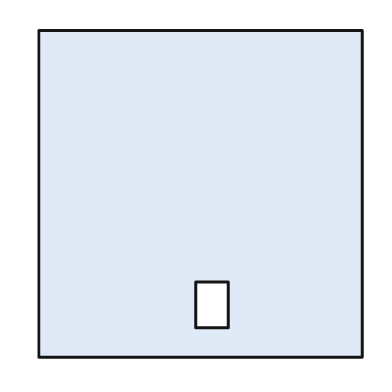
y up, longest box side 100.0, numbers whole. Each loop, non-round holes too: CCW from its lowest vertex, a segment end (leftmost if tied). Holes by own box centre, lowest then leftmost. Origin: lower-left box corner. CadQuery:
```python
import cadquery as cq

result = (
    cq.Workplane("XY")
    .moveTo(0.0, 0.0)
    .lineTo(99.0, 0.0)
    .lineTo(99.0, 100.0)
    .lineTo(0.0, 100.0)
    .close()
    .moveTo(48.0, 9.0)
    .lineTo(58.0, 9.0)
    .lineTo(58.0, 23.0)
    .lineTo(48.0, 23.0)
    .close()
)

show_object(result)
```